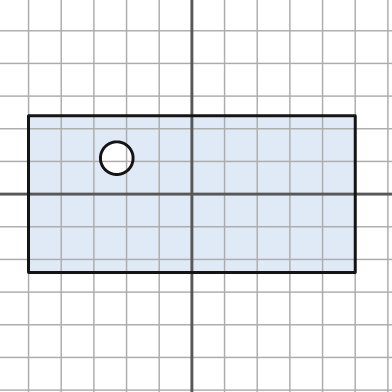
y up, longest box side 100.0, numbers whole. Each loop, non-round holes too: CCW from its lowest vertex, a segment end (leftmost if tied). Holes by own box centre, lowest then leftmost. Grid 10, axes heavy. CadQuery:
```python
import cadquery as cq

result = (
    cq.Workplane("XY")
    .moveTo(-50.0, -24.0)
    .lineTo(50.0, -24.0)
    .lineTo(50.0, 24.0)
    .lineTo(-50.0, 24.0)
    .close()
    .moveTo(-23.0, 11.0)
    .circle(5.0)
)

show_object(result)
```